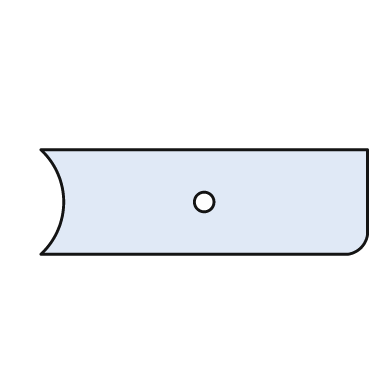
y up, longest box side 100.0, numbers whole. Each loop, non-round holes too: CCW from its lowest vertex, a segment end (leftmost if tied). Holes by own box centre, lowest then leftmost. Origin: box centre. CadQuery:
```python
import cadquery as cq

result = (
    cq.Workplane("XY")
    .moveTo(-50.0, -16.0)
    .lineTo(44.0, -16.0)
    .threePointArc((48.0, -14.0), (50.0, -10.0))
    .lineTo(50.0, 16.0)
    .lineTo(-50.0, 16.0)
    .threePointArc((-43.0, 0.0), (-50.0, -16.0))
    .close()
    .moveTo(0.0, 0.0)
    .circle(3.0)
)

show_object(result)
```